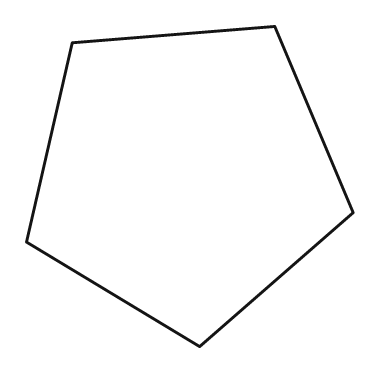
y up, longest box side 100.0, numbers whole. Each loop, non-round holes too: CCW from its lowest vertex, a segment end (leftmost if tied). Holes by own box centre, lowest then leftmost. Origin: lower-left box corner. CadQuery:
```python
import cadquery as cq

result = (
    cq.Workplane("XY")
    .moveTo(53.0, 0.0)
    .lineTo(100.0, 41.0)
    .lineTo(76.0, 98.0)
    .lineTo(14.0, 93.0)
    .lineTo(0.0, 32.0)
    .close()
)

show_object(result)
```